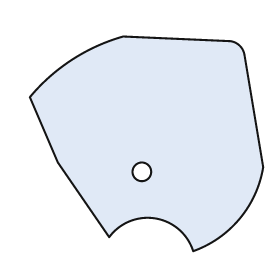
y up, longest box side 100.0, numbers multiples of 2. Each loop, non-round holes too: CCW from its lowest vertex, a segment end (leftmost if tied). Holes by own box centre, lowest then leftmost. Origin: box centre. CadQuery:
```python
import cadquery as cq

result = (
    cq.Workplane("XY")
    .moveTo(20.0, -46.0)
    .threePointArc((40.0, -32.0), (50.0, -10.0))
    .lineTo(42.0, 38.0)
    .threePointArc((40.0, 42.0), (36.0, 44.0))
    .lineTo(-10.0, 46.0)
    .threePointArc((-32.0, 36.0), (-50.0, 20.0))
    .lineTo(-38.0, -8.0)
    .lineTo(-16.0, -40.0)
    .threePointArc((4.0, -32.0), (20.0, -46.0))
    .close()
    .moveTo(-2.0, -12.0)
    .circle(4.0)
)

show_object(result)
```